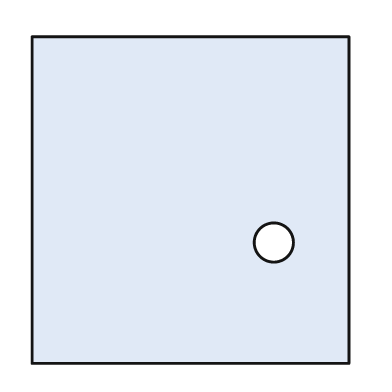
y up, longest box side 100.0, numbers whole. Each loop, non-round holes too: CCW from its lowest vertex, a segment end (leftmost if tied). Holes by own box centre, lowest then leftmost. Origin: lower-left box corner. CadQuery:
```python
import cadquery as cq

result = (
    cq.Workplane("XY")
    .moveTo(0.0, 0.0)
    .lineTo(97.0, 0.0)
    .lineTo(97.0, 100.0)
    .lineTo(0.0, 100.0)
    .close()
    .moveTo(74.0, 37.0)
    .circle(6.0)
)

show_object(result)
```